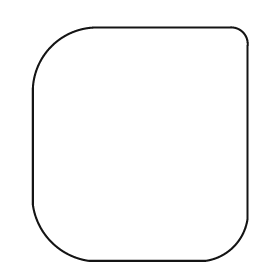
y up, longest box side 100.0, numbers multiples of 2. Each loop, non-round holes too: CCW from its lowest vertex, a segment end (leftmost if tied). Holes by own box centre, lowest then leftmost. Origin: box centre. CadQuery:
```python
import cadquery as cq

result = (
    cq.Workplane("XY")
    .moveTo(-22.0, -50.0)
    .lineTo(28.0, -50.0)
    .threePointArc((40.0, -44.0), (46.0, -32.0))
    .lineTo(46.0, 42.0)
    .threePointArc((44.0, 48.0), (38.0, 50.0))
    .lineTo(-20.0, 50.0)
    .threePointArc((-38.0, 42.0), (-46.0, 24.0))
    .lineTo(-46.0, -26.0)
    .threePointArc((-38.0, -42.0), (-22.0, -50.0))
    .close()
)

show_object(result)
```